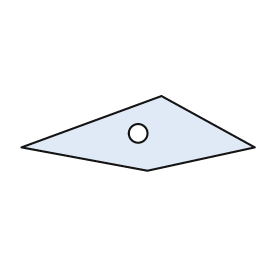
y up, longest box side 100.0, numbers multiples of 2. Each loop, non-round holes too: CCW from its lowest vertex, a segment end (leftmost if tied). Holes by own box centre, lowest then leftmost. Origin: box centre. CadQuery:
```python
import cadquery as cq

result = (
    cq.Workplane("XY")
    .moveTo(4.0, -16.0)
    .lineTo(50.0, -6.0)
    .lineTo(10.0, 16.0)
    .lineTo(-50.0, -6.0)
    .close()
    .moveTo(0.0, 0.0)
    .circle(4.0)
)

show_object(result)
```